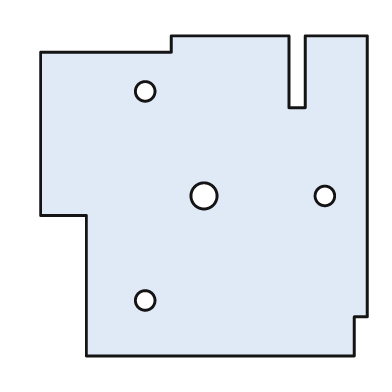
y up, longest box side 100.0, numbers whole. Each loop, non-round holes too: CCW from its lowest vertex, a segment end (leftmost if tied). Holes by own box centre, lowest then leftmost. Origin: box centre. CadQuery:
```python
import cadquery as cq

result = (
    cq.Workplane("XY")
    .moveTo(-36.0, -49.0)
    .lineTo(46.0, -49.0)
    .lineTo(46.0, -37.0)
    .lineTo(50.0, -37.0)
    .lineTo(50.0, 49.0)
    .lineTo(31.0, 49.0)
    .lineTo(31.0, 27.0)
    .lineTo(26.0, 27.0)
    .lineTo(26.0, 49.0)
    .lineTo(-10.0, 49.0)
    .lineTo(-10.0, 44.0)
    .lineTo(-50.0, 44.0)
    .lineTo(-50.0, -6.0)
    .lineTo(-36.0, -6.0)
    .close()
    .moveTo(-18.0, -32.0)
    .circle(3.0)
    .moveTo(0.0, 0.0)
    .circle(4.0)
    .moveTo(37.0, 0.0)
    .circle(3.0)
    .moveTo(-18.0, 32.0)
    .circle(3.0)
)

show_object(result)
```